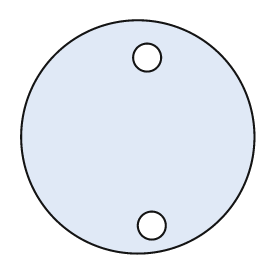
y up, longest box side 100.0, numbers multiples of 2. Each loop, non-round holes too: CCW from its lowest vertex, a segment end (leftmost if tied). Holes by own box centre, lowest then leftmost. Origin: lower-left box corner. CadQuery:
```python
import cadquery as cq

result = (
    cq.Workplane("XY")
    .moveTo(50.0, 50.0)
    .circle(50.0)
    .moveTo(56.0, 12.0)
    .circle(6.0)
    .moveTo(54.0, 84.0)
    .circle(6.0)
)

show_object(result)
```